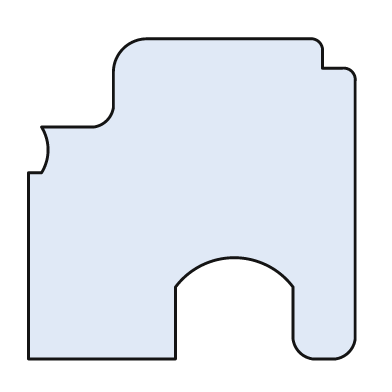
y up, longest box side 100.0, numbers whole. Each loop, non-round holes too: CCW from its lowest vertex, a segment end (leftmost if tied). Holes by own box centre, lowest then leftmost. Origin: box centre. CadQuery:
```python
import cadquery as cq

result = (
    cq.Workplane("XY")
    .moveTo(-50.0, -49.0)
    .lineTo(-5.0, -49.0)
    .lineTo(-5.0, -27.0)
    .threePointArc((13.0, -18.0), (31.0, -27.0))
    .lineTo(31.0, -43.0)
    .threePointArc((33.0, -47.0), (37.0, -49.0))
    .lineTo(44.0, -49.0)
    .threePointArc((48.0, -47.0), (50.0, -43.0))
    .lineTo(50.0, 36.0)
    .threePointArc((49.0, 39.0), (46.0, 40.0))
    .lineTo(40.0, 40.0)
    .lineTo(40.0, 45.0)
    .threePointArc((39.0, 48.0), (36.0, 49.0))
    .lineTo(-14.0, 49.0)
    .threePointArc((-21.0, 46.0), (-24.0, 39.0))
    .lineTo(-24.0, 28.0)
    .threePointArc((-26.0, 24.0), (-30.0, 22.0))
    .lineTo(-46.0, 22.0)
    .threePointArc((-44.0, 15.0), (-46.0, 8.0))
    .lineTo(-50.0, 8.0)
    .close()
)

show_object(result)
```